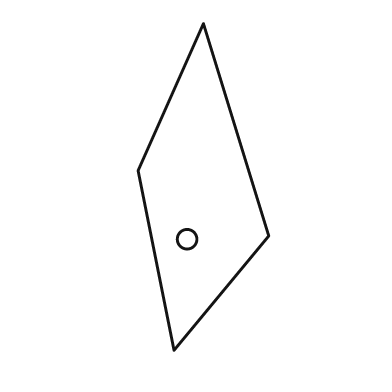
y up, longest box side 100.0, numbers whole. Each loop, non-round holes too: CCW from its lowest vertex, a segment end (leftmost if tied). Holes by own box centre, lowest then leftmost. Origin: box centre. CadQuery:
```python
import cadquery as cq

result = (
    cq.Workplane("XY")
    .moveTo(-9.0, -50.0)
    .lineTo(20.0, -15.0)
    .lineTo(0.0, 50.0)
    .lineTo(-20.0, 5.0)
    .close()
    .moveTo(-5.0, -16.0)
    .circle(3.0)
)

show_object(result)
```